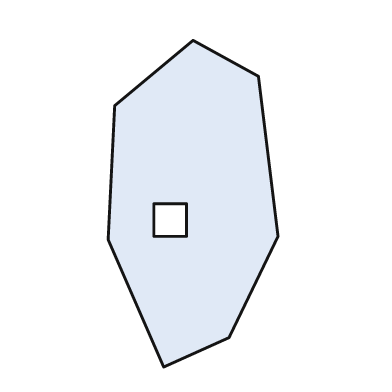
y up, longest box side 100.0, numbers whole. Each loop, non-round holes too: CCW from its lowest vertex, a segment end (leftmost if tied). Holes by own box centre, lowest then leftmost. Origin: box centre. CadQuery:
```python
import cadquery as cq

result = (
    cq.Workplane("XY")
    .moveTo(-9.0, -50.0)
    .lineTo(11.0, -41.0)
    .lineTo(26.0, -10.0)
    .lineTo(20.0, 39.0)
    .lineTo(0.0, 50.0)
    .lineTo(-24.0, 30.0)
    .lineTo(-26.0, -11.0)
    .close()
    .moveTo(-12.0, -10.0)
    .lineTo(-2.0, -10.0)
    .lineTo(-2.0, 0.0)
    .lineTo(-12.0, 0.0)
    .close()
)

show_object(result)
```